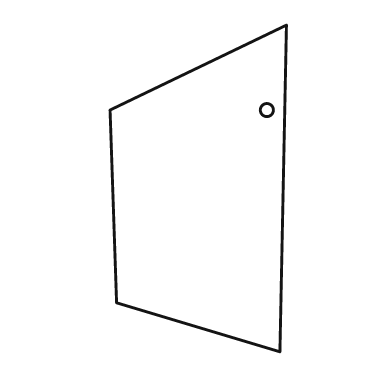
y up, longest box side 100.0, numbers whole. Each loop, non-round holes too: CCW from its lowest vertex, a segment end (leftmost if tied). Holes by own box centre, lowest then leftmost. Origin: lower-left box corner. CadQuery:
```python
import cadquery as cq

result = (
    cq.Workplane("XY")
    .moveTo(52.0, 0.0)
    .lineTo(54.0, 100.0)
    .lineTo(0.0, 74.0)
    .lineTo(2.0, 15.0)
    .close()
    .moveTo(48.0, 74.0)
    .circle(2.0)
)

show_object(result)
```